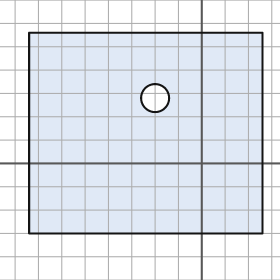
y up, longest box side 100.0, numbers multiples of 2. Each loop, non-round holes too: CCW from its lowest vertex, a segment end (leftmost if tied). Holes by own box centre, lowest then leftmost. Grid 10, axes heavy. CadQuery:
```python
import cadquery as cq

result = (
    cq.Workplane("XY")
    .moveTo(-74.0, -30.0)
    .lineTo(26.0, -30.0)
    .lineTo(26.0, 56.0)
    .lineTo(-74.0, 56.0)
    .close()
    .moveTo(-20.0, 28.0)
    .circle(6.0)
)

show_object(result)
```